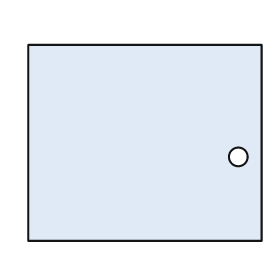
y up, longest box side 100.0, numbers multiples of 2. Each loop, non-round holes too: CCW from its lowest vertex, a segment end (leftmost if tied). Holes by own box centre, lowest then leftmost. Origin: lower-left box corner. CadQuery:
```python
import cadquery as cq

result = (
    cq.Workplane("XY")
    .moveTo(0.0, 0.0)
    .lineTo(100.0, 0.0)
    .lineTo(100.0, 84.0)
    .lineTo(0.0, 84.0)
    .close()
    .moveTo(90.0, 36.0)
    .circle(4.0)
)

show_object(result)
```